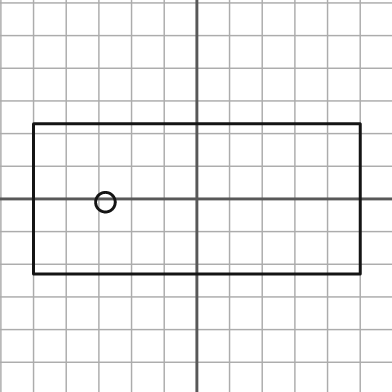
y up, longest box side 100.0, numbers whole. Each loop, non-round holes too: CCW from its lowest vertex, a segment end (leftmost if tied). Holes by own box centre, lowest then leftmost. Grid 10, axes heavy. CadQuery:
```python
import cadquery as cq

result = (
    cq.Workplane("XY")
    .moveTo(-50.0, -23.0)
    .lineTo(50.0, -23.0)
    .lineTo(50.0, 23.0)
    .lineTo(-50.0, 23.0)
    .close()
    .moveTo(-28.0, -1.0)
    .circle(3.0)
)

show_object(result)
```